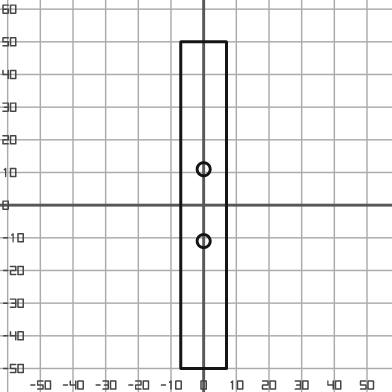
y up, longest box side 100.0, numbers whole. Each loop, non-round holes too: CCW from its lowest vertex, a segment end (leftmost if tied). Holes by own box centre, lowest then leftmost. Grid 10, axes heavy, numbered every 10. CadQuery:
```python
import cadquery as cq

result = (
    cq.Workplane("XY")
    .moveTo(-7.0, -50.0)
    .lineTo(7.0, -50.0)
    .lineTo(7.0, 50.0)
    .lineTo(-7.0, 50.0)
    .close()
    .moveTo(0.0, -11.0)
    .circle(2.0)
    .moveTo(0.0, 11.0)
    .circle(2.0)
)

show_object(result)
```